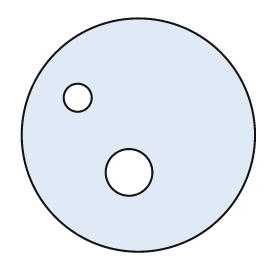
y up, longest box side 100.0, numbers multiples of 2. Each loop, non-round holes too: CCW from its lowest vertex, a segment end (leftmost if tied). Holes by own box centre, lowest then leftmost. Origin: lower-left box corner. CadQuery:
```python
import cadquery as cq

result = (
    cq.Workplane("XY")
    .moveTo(50.0, 50.0)
    .circle(50.0)
    .moveTo(46.0, 34.0)
    .circle(10.0)
    .moveTo(24.0, 66.0)
    .circle(6.0)
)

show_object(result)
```